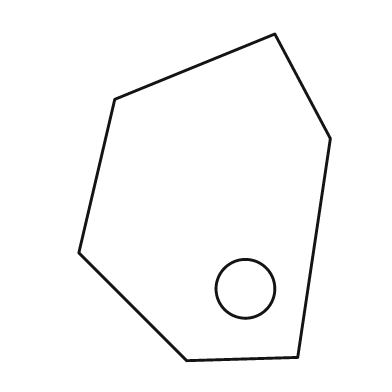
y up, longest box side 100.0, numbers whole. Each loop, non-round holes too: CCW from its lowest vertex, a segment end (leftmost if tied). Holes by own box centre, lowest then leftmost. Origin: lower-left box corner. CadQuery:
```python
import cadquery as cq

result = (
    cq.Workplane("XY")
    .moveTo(33.0, 0.0)
    .lineTo(67.0, 1.0)
    .lineTo(77.0, 68.0)
    .lineTo(60.0, 100.0)
    .lineTo(11.0, 80.0)
    .lineTo(0.0, 33.0)
    .close()
    .moveTo(51.0, 22.0)
    .circle(9.0)
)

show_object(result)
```